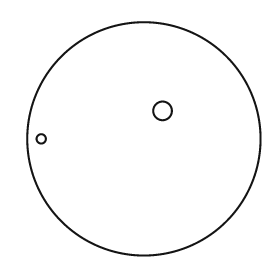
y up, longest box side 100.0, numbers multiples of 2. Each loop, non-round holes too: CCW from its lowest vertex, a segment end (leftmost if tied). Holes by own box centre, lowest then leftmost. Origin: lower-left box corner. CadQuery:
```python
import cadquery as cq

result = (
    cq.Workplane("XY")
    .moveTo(50.0, 50.0)
    .circle(50.0)
    .moveTo(6.0, 50.0)
    .circle(2.0)
    .moveTo(58.0, 62.0)
    .circle(4.0)
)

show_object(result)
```